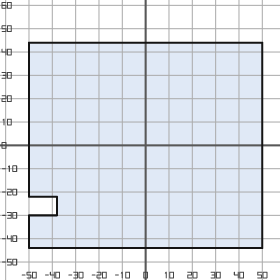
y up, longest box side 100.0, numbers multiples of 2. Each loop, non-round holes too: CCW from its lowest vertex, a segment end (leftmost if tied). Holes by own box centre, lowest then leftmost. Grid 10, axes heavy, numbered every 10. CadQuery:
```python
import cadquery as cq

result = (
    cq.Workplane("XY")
    .moveTo(-50.0, -44.0)
    .lineTo(50.0, -44.0)
    .lineTo(50.0, 44.0)
    .lineTo(-50.0, 44.0)
    .lineTo(-50.0, -22.0)
    .lineTo(-38.0, -22.0)
    .lineTo(-38.0, -30.0)
    .lineTo(-50.0, -30.0)
    .close()
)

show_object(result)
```